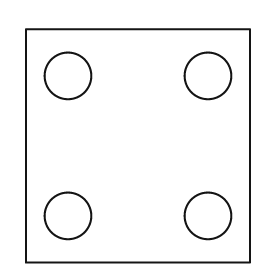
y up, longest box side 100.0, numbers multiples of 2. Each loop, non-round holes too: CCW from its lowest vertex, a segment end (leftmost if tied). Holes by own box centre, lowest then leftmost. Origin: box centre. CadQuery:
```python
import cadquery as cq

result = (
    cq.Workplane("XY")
    .moveTo(-48.0, -50.0)
    .lineTo(48.0, -50.0)
    .lineTo(48.0, 50.0)
    .lineTo(-48.0, 50.0)
    .close()
    .moveTo(-30.0, -30.0)
    .circle(10.0)
    .moveTo(30.0, -30.0)
    .circle(10.0)
    .moveTo(-30.0, 30.0)
    .circle(10.0)
    .moveTo(30.0, 30.0)
    .circle(10.0)
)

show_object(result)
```